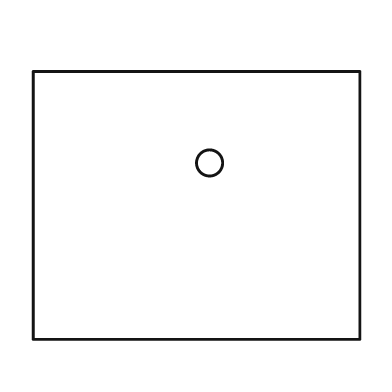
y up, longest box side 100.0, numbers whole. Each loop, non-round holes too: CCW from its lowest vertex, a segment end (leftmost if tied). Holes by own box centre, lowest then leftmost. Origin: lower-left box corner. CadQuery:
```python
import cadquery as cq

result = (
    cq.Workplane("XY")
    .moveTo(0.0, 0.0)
    .lineTo(100.0, 0.0)
    .lineTo(100.0, 82.0)
    .lineTo(0.0, 82.0)
    .close()
    .moveTo(54.0, 54.0)
    .circle(4.0)
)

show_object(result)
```